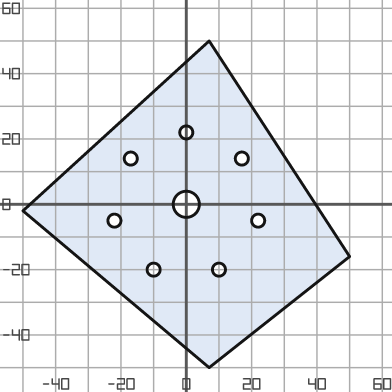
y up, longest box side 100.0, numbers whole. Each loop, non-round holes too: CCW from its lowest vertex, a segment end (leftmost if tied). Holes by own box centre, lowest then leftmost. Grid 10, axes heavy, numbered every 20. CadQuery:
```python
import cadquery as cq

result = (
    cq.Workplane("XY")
    .moveTo(7.0, -50.0)
    .lineTo(50.0, -16.0)
    .lineTo(7.0, 50.0)
    .lineTo(-50.0, -2.0)
    .close()
    .moveTo(-10.0, -20.0)
    .circle(2.0)
    .moveTo(10.0, -20.0)
    .circle(2.0)
    .moveTo(-22.0, -5.0)
    .circle(2.0)
    .moveTo(22.0, -5.0)
    .circle(2.0)
    .moveTo(0.0, 0.0)
    .circle(4.0)
    .moveTo(-17.0, 14.0)
    .circle(2.0)
    .moveTo(17.0, 14.0)
    .circle(2.0)
    .moveTo(0.0, 22.0)
    .circle(2.0)
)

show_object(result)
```